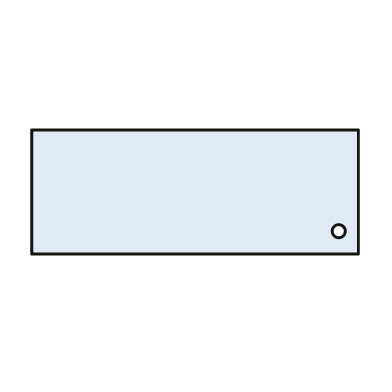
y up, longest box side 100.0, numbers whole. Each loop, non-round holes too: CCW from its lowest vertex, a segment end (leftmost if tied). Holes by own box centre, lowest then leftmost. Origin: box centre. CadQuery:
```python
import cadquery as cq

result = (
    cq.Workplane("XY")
    .moveTo(-50.0, -19.0)
    .lineTo(50.0, -19.0)
    .lineTo(50.0, 19.0)
    .lineTo(-50.0, 19.0)
    .close()
    .moveTo(44.0, -12.0)
    .circle(2.0)
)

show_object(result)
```